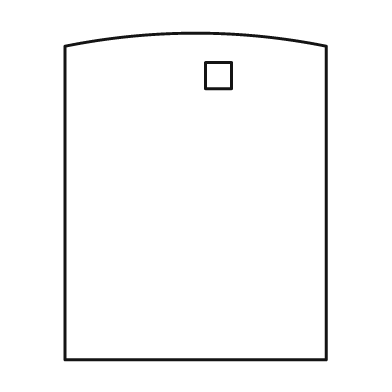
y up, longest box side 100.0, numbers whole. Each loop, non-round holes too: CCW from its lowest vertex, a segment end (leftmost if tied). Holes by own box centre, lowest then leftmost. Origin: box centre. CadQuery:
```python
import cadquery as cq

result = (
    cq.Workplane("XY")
    .moveTo(-40.0, -50.0)
    .lineTo(40.0, -50.0)
    .lineTo(40.0, 46.0)
    .threePointArc((0.0, 50.0), (-40.0, 46.0))
    .close()
    .moveTo(3.0, 33.0)
    .lineTo(11.0, 33.0)
    .lineTo(11.0, 41.0)
    .lineTo(3.0, 41.0)
    .close()
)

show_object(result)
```